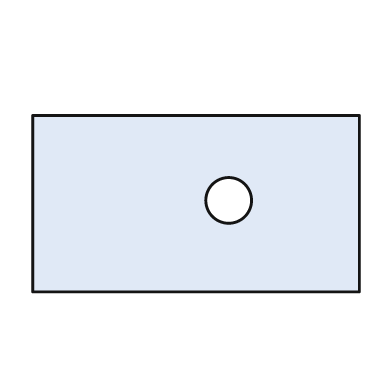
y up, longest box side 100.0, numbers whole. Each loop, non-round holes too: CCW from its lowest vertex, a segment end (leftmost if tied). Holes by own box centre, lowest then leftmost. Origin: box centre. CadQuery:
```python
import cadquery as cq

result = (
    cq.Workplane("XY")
    .moveTo(-50.0, -27.0)
    .lineTo(50.0, -27.0)
    .lineTo(50.0, 27.0)
    .lineTo(-50.0, 27.0)
    .close()
    .moveTo(10.0, 1.0)
    .circle(7.0)
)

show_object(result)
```